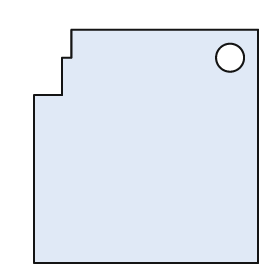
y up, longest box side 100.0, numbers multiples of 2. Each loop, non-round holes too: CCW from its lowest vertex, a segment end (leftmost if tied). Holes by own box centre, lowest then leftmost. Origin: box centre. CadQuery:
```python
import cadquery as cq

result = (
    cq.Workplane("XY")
    .moveTo(-48.0, -50.0)
    .lineTo(48.0, -50.0)
    .lineTo(48.0, 50.0)
    .lineTo(-32.0, 50.0)
    .lineTo(-32.0, 38.0)
    .lineTo(-36.0, 38.0)
    .lineTo(-36.0, 22.0)
    .lineTo(-48.0, 22.0)
    .close()
    .moveTo(36.0, 38.0)
    .circle(6.0)
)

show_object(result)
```